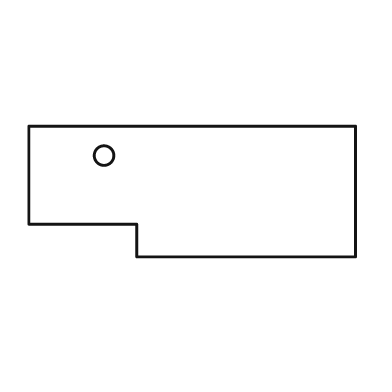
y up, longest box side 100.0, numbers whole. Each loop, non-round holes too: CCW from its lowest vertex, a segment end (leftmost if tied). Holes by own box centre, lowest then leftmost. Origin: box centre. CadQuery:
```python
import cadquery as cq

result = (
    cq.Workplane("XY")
    .moveTo(-17.0, -20.0)
    .lineTo(50.0, -20.0)
    .lineTo(50.0, 20.0)
    .lineTo(-50.0, 20.0)
    .lineTo(-50.0, -10.0)
    .lineTo(-17.0, -10.0)
    .close()
    .moveTo(-27.0, 11.0)
    .circle(3.0)
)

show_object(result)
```